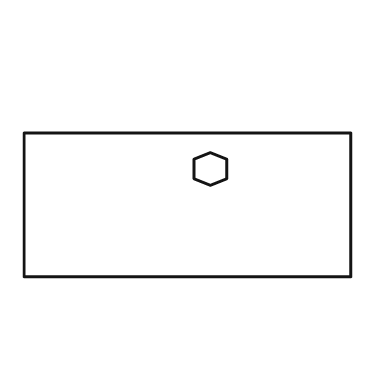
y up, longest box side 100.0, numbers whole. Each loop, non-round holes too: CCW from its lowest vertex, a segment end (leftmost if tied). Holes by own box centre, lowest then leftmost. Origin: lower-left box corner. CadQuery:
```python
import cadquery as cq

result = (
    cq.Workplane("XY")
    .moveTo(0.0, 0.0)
    .lineTo(100.0, 0.0)
    .lineTo(100.0, 44.0)
    .lineTo(0.0, 44.0)
    .close()
    .moveTo(57.0, 28.0)
    .lineTo(62.0, 30.0)
    .lineTo(62.0, 36.0)
    .lineTo(57.0, 38.0)
    .lineTo(52.0, 36.0)
    .lineTo(52.0, 30.0)
    .close()
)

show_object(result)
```